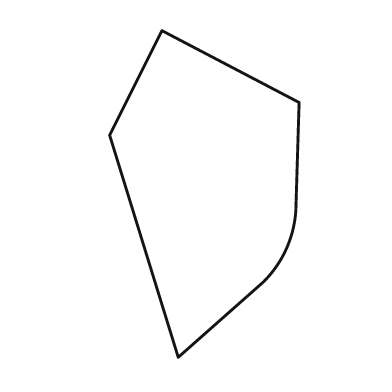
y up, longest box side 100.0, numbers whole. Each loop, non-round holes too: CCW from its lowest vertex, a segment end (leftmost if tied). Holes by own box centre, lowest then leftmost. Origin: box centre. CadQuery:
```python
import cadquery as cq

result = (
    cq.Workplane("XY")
    .moveTo(-8.0, -50.0)
    .lineTo(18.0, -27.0)
    .threePointArc((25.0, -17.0), (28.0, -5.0))
    .lineTo(29.0, 28.0)
    .lineTo(-13.0, 50.0)
    .lineTo(-29.0, 18.0)
    .close()
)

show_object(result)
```